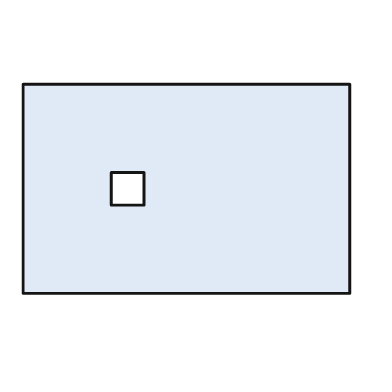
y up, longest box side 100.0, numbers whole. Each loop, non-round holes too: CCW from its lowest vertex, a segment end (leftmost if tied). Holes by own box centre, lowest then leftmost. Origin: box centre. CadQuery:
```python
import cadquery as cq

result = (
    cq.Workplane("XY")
    .moveTo(-50.0, -32.0)
    .lineTo(50.0, -32.0)
    .lineTo(50.0, 32.0)
    .lineTo(-50.0, 32.0)
    .close()
    .moveTo(-23.0, -5.0)
    .lineTo(-13.0, -5.0)
    .lineTo(-13.0, 5.0)
    .lineTo(-23.0, 5.0)
    .close()
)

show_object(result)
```